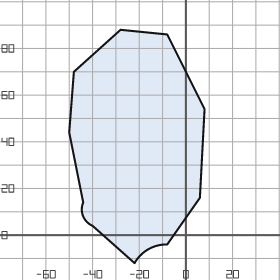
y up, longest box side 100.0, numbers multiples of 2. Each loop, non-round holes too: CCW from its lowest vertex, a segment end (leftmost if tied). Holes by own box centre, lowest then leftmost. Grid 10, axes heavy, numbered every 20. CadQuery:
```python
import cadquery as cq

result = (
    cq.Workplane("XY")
    .moveTo(-22.0, -12.0)
    .threePointArc((-16.0, -6.0), (-8.0, -4.0))
    .lineTo(6.0, 16.0)
    .lineTo(8.0, 54.0)
    .lineTo(-8.0, 86.0)
    .lineTo(-28.0, 88.0)
    .lineTo(-48.0, 70.0)
    .lineTo(-50.0, 44.0)
    .lineTo(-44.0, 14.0)
    .threePointArc((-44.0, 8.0), (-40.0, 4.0))
    .close()
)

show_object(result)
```